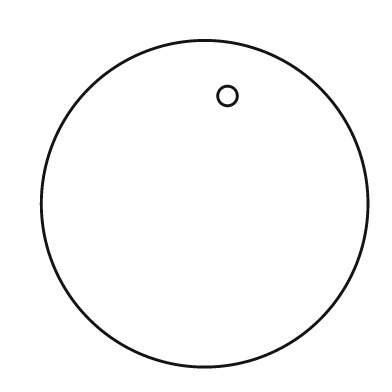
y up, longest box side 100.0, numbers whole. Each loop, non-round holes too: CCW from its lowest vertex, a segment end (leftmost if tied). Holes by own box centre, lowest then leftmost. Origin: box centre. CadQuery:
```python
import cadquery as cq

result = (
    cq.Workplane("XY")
    .moveTo(0.0, 0.0)
    .circle(50.0)
    .moveTo(7.0, 33.0)
    .circle(3.0)
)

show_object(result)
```